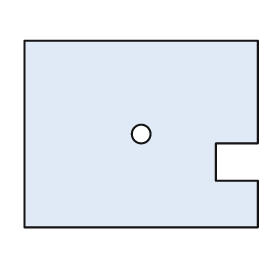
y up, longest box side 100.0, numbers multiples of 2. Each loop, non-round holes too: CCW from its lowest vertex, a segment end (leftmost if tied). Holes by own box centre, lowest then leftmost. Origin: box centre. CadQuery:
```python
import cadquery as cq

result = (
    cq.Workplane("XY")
    .moveTo(-50.0, -40.0)
    .lineTo(50.0, -40.0)
    .lineTo(50.0, -20.0)
    .lineTo(32.0, -20.0)
    .lineTo(32.0, -4.0)
    .lineTo(50.0, -4.0)
    .lineTo(50.0, 40.0)
    .lineTo(-50.0, 40.0)
    .close()
    .moveTo(0.0, 0.0)
    .circle(4.0)
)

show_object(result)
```